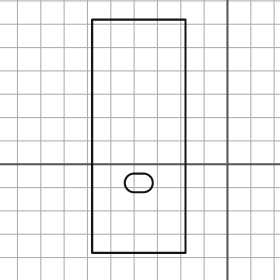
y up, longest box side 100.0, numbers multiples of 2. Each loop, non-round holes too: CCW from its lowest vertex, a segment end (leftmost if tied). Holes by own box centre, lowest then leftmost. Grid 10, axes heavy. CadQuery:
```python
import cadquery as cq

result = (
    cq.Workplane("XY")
    .moveTo(-58.0, -38.0)
    .lineTo(-18.0, -38.0)
    .lineTo(-18.0, 62.0)
    .lineTo(-58.0, 62.0)
    .close()
    .moveTo(-40.0, -12.0)
    .lineTo(-36.0, -12.0)
    .threePointArc((-32.0, -8.0), (-36.0, -4.0))
    .lineTo(-40.0, -4.0)
    .threePointArc((-44.0, -8.0), (-40.0, -12.0))
    .close()
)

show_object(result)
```